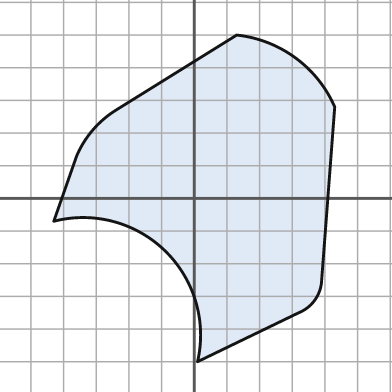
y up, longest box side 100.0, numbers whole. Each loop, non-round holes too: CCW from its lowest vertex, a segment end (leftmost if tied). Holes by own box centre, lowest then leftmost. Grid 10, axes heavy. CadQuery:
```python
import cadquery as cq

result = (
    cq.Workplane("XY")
    .moveTo(1.0, -50.0)
    .lineTo(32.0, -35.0)
    .threePointArc((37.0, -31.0), (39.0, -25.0))
    .lineTo(43.0, 28.0)
    .threePointArc((31.0, 43.0), (13.0, 50.0))
    .lineTo(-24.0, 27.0)
    .threePointArc((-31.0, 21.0), (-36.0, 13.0))
    .lineTo(-43.0, -7.0)
    .threePointArc((-9.0, -16.0), (1.0, -50.0))
    .close()
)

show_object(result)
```